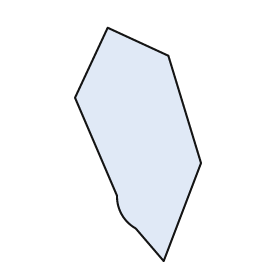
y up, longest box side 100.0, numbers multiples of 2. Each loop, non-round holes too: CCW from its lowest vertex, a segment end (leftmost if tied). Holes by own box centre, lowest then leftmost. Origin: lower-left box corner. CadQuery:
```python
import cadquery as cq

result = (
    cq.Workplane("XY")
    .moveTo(38.0, 0.0)
    .lineTo(54.0, 42.0)
    .lineTo(40.0, 88.0)
    .lineTo(14.0, 100.0)
    .lineTo(0.0, 70.0)
    .lineTo(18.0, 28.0)
    .threePointArc((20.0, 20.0), (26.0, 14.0))
    .close()
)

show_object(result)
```